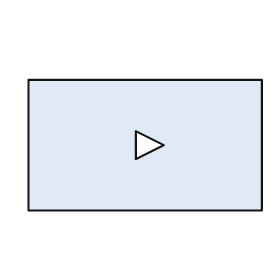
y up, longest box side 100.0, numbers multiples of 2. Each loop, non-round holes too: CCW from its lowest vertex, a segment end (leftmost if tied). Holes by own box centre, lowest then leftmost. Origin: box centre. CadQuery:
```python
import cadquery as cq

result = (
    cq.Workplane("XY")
    .moveTo(-50.0, -28.0)
    .lineTo(50.0, -28.0)
    .lineTo(50.0, 28.0)
    .lineTo(-50.0, 28.0)
    .close()
    .moveTo(-4.0, -6.0)
    .lineTo(8.0, 0.0)
    .lineTo(-4.0, 6.0)
    .close()
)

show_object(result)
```